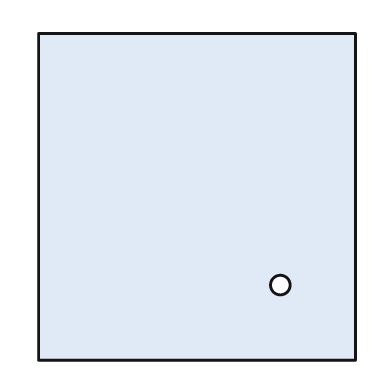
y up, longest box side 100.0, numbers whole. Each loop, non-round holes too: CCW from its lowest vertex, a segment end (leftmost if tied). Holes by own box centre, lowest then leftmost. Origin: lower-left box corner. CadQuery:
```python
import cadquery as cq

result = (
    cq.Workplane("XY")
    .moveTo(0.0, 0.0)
    .lineTo(97.0, 0.0)
    .lineTo(97.0, 100.0)
    .lineTo(0.0, 100.0)
    .close()
    .moveTo(74.0, 23.0)
    .circle(3.0)
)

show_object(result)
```